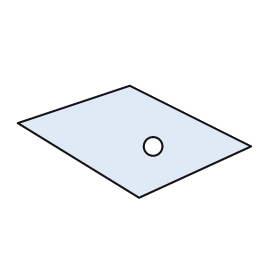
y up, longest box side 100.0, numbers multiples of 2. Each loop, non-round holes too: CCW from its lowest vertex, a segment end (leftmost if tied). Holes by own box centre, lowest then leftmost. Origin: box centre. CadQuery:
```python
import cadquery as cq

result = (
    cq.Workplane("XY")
    .moveTo(2.0, -24.0)
    .lineTo(50.0, -2.0)
    .lineTo(-2.0, 24.0)
    .lineTo(-50.0, 8.0)
    .close()
    .moveTo(8.0, -2.0)
    .circle(4.0)
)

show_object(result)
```